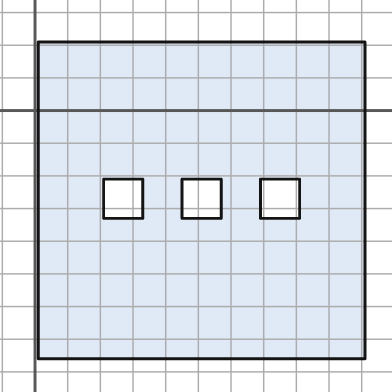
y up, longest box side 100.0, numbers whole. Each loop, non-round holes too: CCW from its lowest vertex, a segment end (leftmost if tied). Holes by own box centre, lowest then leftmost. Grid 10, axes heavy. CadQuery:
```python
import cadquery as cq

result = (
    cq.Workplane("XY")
    .moveTo(1.0, -76.0)
    .lineTo(101.0, -76.0)
    .lineTo(101.0, 21.0)
    .lineTo(1.0, 21.0)
    .close()
    .moveTo(21.0, -33.0)
    .lineTo(33.0, -33.0)
    .lineTo(33.0, -21.0)
    .lineTo(21.0, -21.0)
    .close()
    .moveTo(45.0, -33.0)
    .lineTo(57.0, -33.0)
    .lineTo(57.0, -21.0)
    .lineTo(45.0, -21.0)
    .close()
    .moveTo(69.0, -33.0)
    .lineTo(81.0, -33.0)
    .lineTo(81.0, -21.0)
    .lineTo(69.0, -21.0)
    .close()
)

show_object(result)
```